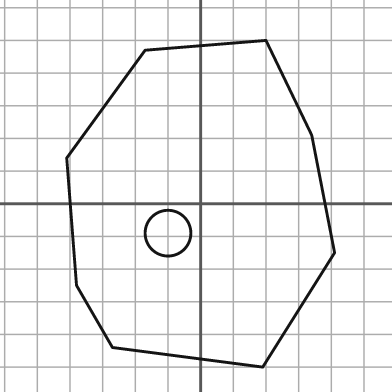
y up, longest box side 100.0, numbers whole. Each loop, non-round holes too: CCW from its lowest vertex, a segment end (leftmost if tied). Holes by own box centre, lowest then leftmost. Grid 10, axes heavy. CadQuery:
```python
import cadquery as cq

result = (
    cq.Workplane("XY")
    .moveTo(19.0, -50.0)
    .lineTo(41.0, -15.0)
    .lineTo(34.0, 21.0)
    .lineTo(20.0, 50.0)
    .lineTo(-17.0, 47.0)
    .lineTo(-41.0, 14.0)
    .lineTo(-38.0, -25.0)
    .lineTo(-27.0, -44.0)
    .close()
    .moveTo(-10.0, -9.0)
    .circle(7.0)
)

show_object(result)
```